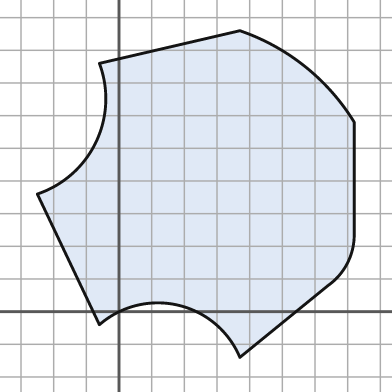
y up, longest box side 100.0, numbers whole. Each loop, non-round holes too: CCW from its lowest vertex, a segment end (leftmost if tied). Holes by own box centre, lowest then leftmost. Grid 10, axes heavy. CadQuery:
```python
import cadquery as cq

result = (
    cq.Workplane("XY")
    .moveTo(37.0, -14.0)
    .lineTo(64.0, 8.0)
    .threePointArc((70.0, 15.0), (72.0, 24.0))
    .lineTo(72.0, 58.0)
    .threePointArc((57.0, 75.0), (37.0, 86.0))
    .lineTo(-6.0, 76.0)
    .threePointArc((-7.0, 52.0), (-25.0, 36.0))
    .lineTo(-6.0, -4.0)
    .threePointArc((18.0, 2.0), (37.0, -14.0))
    .close()
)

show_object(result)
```